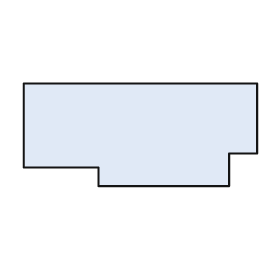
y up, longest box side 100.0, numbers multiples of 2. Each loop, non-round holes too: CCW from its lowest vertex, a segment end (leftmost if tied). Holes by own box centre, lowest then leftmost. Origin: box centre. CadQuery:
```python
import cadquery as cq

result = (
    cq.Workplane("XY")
    .moveTo(-18.0, -22.0)
    .lineTo(38.0, -22.0)
    .lineTo(38.0, -8.0)
    .lineTo(50.0, -8.0)
    .lineTo(50.0, 22.0)
    .lineTo(-50.0, 22.0)
    .lineTo(-50.0, -14.0)
    .lineTo(-18.0, -14.0)
    .close()
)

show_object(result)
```